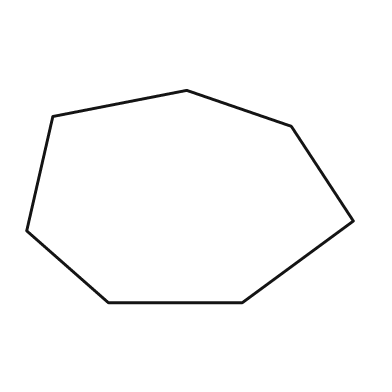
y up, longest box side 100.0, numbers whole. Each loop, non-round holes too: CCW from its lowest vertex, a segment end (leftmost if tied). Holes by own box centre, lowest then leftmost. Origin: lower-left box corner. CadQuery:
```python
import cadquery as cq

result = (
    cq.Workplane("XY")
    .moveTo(25.0, 0.0)
    .lineTo(66.0, 0.0)
    .lineTo(100.0, 25.0)
    .lineTo(81.0, 54.0)
    .lineTo(49.0, 65.0)
    .lineTo(8.0, 57.0)
    .lineTo(0.0, 22.0)
    .close()
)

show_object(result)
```